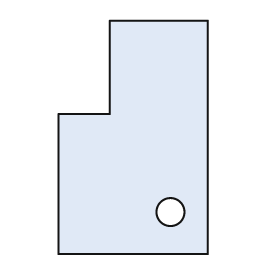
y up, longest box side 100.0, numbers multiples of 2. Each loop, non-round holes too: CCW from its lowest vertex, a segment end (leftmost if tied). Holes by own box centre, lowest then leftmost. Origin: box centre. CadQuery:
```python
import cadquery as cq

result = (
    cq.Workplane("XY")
    .moveTo(-32.0, -50.0)
    .lineTo(32.0, -50.0)
    .lineTo(32.0, 50.0)
    .lineTo(-10.0, 50.0)
    .lineTo(-10.0, 10.0)
    .lineTo(-32.0, 10.0)
    .close()
    .moveTo(16.0, -32.0)
    .circle(6.0)
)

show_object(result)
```